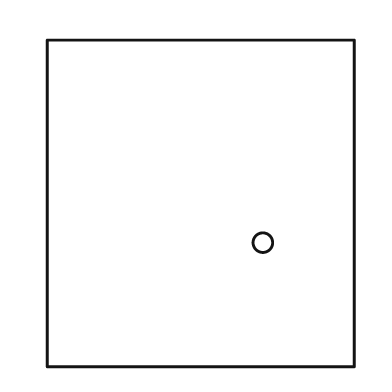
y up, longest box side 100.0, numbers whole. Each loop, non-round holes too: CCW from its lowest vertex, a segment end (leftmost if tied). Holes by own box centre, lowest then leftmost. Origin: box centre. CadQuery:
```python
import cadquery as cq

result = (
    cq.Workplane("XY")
    .moveTo(-47.0, -50.0)
    .lineTo(47.0, -50.0)
    .lineTo(47.0, 50.0)
    .lineTo(-47.0, 50.0)
    .close()
    .moveTo(19.0, -12.0)
    .circle(3.0)
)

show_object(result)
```